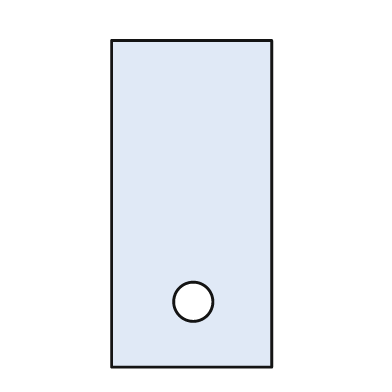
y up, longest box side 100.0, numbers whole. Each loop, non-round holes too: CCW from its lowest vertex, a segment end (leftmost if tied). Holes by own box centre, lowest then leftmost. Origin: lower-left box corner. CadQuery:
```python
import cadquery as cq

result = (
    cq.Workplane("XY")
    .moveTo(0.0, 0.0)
    .lineTo(49.0, 0.0)
    .lineTo(49.0, 100.0)
    .lineTo(0.0, 100.0)
    .close()
    .moveTo(25.0, 20.0)
    .circle(6.0)
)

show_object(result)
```